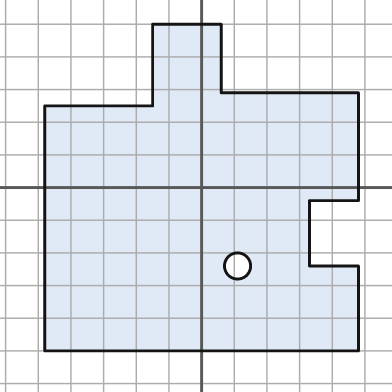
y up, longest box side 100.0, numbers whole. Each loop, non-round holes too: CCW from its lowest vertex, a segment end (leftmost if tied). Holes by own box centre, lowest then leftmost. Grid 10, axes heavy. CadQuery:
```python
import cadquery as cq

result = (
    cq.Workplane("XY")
    .moveTo(-48.0, -50.0)
    .lineTo(48.0, -50.0)
    .lineTo(48.0, -24.0)
    .lineTo(33.0, -24.0)
    .lineTo(33.0, -4.0)
    .lineTo(48.0, -4.0)
    .lineTo(48.0, 29.0)
    .lineTo(6.0, 29.0)
    .lineTo(6.0, 50.0)
    .lineTo(-15.0, 50.0)
    .lineTo(-15.0, 25.0)
    .lineTo(-48.0, 25.0)
    .close()
    .moveTo(11.0, -24.0)
    .circle(4.0)
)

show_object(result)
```